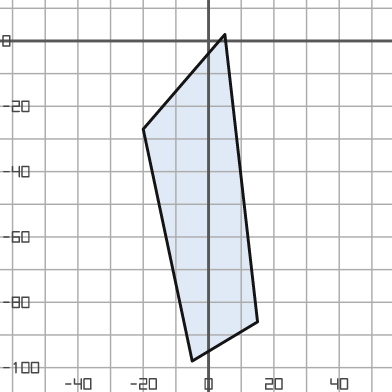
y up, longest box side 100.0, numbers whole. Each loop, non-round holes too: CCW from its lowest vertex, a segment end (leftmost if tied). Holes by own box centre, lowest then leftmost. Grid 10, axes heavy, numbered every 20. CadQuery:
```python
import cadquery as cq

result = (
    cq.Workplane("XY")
    .moveTo(-5.0, -98.0)
    .lineTo(15.0, -86.0)
    .lineTo(5.0, 2.0)
    .lineTo(-20.0, -27.0)
    .close()
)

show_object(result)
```